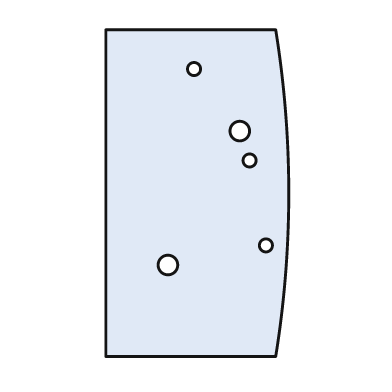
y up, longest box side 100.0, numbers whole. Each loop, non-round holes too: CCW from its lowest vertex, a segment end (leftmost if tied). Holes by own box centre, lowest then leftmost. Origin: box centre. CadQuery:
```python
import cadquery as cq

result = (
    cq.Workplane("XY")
    .moveTo(-28.0, -50.0)
    .lineTo(24.0, -50.0)
    .threePointArc((28.0, 0.0), (24.0, 50.0))
    .lineTo(-28.0, 50.0)
    .close()
    .moveTo(-9.0, -22.0)
    .circle(3.0)
    .moveTo(21.0, -16.0)
    .circle(2.0)
    .moveTo(16.0, 10.0)
    .circle(2.0)
    .moveTo(13.0, 19.0)
    .circle(3.0)
    .moveTo(-1.0, 38.0)
    .circle(2.0)
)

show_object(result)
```